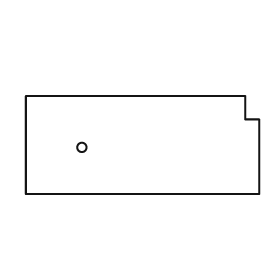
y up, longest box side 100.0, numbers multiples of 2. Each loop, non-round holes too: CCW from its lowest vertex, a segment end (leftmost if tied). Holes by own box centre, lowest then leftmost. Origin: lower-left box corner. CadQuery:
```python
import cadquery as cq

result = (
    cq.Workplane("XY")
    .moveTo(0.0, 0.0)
    .lineTo(100.0, 0.0)
    .lineTo(100.0, 32.0)
    .lineTo(94.0, 32.0)
    .lineTo(94.0, 42.0)
    .lineTo(0.0, 42.0)
    .close()
    .moveTo(24.0, 20.0)
    .circle(2.0)
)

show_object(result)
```